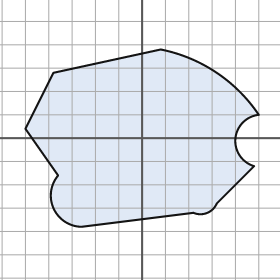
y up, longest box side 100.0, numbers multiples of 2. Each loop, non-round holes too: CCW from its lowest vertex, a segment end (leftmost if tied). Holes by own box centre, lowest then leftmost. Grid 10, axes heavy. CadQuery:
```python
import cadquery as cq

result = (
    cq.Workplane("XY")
    .moveTo(-26.0, -38.0)
    .lineTo(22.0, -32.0)
    .threePointArc((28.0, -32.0), (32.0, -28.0))
    .lineTo(48.0, -12.0)
    .threePointArc((40.0, 0.0), (50.0, 10.0))
    .threePointArc((32.0, 28.0), (8.0, 38.0))
    .lineTo(-38.0, 28.0)
    .lineTo(-50.0, 4.0)
    .lineTo(-36.0, -16.0)
    .threePointArc((-38.0, -30.0), (-26.0, -38.0))
    .close()
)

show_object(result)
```